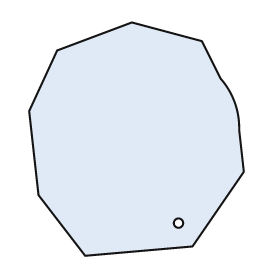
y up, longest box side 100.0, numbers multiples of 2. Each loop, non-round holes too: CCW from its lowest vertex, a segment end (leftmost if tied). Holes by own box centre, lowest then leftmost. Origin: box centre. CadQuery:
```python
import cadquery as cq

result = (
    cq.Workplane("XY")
    .moveTo(-22.0, -50.0)
    .lineTo(24.0, -46.0)
    .lineTo(46.0, -14.0)
    .lineTo(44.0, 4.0)
    .threePointArc((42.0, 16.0), (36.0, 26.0))
    .lineTo(28.0, 42.0)
    .lineTo(-2.0, 50.0)
    .lineTo(-34.0, 38.0)
    .lineTo(-46.0, 12.0)
    .lineTo(-42.0, -24.0)
    .close()
    .moveTo(18.0, -36.0)
    .circle(2.0)
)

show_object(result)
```